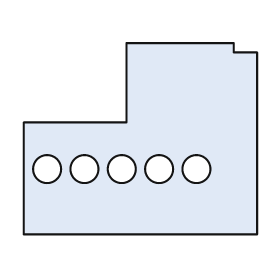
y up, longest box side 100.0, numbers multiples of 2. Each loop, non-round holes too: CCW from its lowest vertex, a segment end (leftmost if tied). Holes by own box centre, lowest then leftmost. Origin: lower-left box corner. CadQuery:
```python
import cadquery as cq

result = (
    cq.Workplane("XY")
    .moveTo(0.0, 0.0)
    .lineTo(100.0, 0.0)
    .lineTo(100.0, 78.0)
    .lineTo(90.0, 78.0)
    .lineTo(90.0, 82.0)
    .lineTo(44.0, 82.0)
    .lineTo(44.0, 48.0)
    .lineTo(0.0, 48.0)
    .close()
    .moveTo(10.0, 28.0)
    .circle(6.0)
    .moveTo(26.0, 28.0)
    .circle(6.0)
    .moveTo(42.0, 28.0)
    .circle(6.0)
    .moveTo(58.0, 28.0)
    .circle(6.0)
    .moveTo(74.0, 28.0)
    .circle(6.0)
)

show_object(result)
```